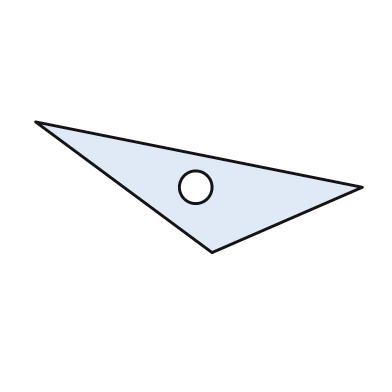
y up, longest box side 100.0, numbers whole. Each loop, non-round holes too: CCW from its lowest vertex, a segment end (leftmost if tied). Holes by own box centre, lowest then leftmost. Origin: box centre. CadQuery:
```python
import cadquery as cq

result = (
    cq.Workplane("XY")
    .moveTo(4.0, -20.0)
    .lineTo(50.0, 0.0)
    .lineTo(-50.0, 20.0)
    .close()
    .moveTo(-1.0, 0.0)
    .circle(5.0)
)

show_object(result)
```